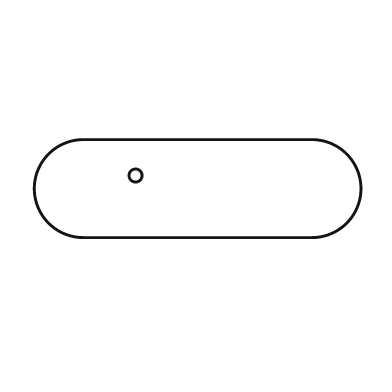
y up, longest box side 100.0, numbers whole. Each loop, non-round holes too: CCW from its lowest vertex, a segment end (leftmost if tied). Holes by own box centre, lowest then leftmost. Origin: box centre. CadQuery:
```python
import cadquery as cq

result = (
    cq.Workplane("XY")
    .moveTo(-35.0, -15.0)
    .lineTo(35.0, -15.0)
    .threePointArc((50.0, 0.0), (35.0, 15.0))
    .lineTo(-35.0, 15.0)
    .threePointArc((-50.0, 0.0), (-35.0, -15.0))
    .close()
    .moveTo(-19.0, 4.0)
    .circle(2.0)
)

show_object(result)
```